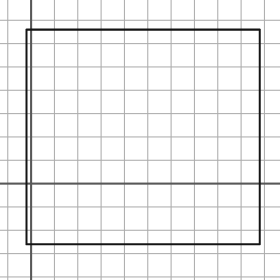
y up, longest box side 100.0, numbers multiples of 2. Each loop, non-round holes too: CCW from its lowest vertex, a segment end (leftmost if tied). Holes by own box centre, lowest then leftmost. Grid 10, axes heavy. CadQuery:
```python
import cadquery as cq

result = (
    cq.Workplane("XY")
    .moveTo(-2.0, -26.0)
    .lineTo(98.0, -26.0)
    .lineTo(98.0, 66.0)
    .lineTo(-2.0, 66.0)
    .close()
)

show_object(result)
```